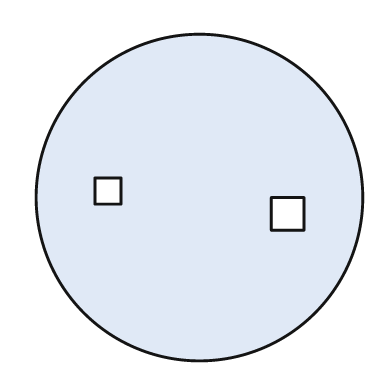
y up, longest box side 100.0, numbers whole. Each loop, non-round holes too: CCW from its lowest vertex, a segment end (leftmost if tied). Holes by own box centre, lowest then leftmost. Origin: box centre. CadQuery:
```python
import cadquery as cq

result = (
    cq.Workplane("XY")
    .moveTo(0.0, 0.0)
    .circle(50.0)
    .moveTo(22.0, -10.0)
    .lineTo(32.0, -10.0)
    .lineTo(32.0, 0.0)
    .lineTo(22.0, 0.0)
    .close()
    .moveTo(-32.0, -2.0)
    .lineTo(-24.0, -2.0)
    .lineTo(-24.0, 6.0)
    .lineTo(-32.0, 6.0)
    .close()
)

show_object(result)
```